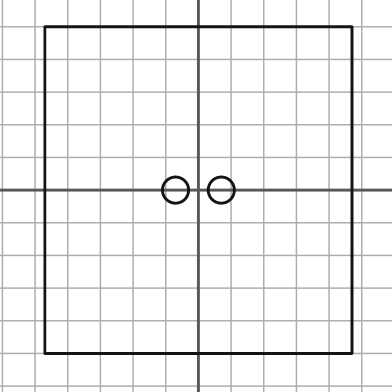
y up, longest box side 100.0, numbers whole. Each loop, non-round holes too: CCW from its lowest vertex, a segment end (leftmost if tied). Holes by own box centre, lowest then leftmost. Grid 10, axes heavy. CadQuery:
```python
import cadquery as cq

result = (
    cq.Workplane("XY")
    .moveTo(-47.0, -50.0)
    .lineTo(47.0, -50.0)
    .lineTo(47.0, 50.0)
    .lineTo(-47.0, 50.0)
    .close()
    .moveTo(-7.0, 0.0)
    .circle(4.0)
    .moveTo(7.0, 0.0)
    .circle(4.0)
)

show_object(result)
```